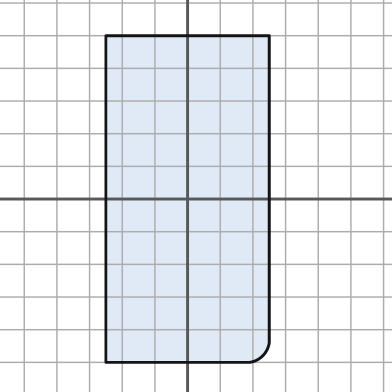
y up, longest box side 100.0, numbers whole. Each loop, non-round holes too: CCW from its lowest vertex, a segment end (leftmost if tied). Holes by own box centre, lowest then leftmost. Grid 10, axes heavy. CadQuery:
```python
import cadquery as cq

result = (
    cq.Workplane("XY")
    .moveTo(-25.0, -50.0)
    .lineTo(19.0, -50.0)
    .threePointArc((23.0, -48.0), (25.0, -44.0))
    .lineTo(25.0, 50.0)
    .lineTo(-25.0, 50.0)
    .close()
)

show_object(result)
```